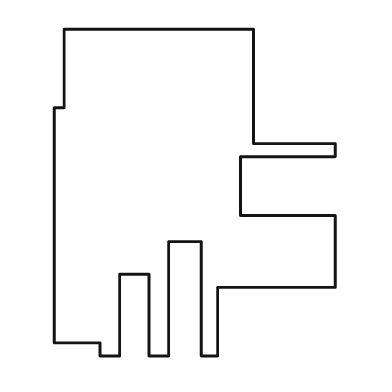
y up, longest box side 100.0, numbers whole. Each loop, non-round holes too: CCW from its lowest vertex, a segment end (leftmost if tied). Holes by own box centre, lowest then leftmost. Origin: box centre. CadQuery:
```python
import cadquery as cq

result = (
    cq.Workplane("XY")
    .moveTo(-29.0, -50.0)
    .lineTo(-23.0, -50.0)
    .lineTo(-23.0, -25.0)
    .lineTo(-14.0, -25.0)
    .lineTo(-14.0, -50.0)
    .lineTo(-8.0, -50.0)
    .lineTo(-8.0, -15.0)
    .lineTo(2.0, -15.0)
    .lineTo(2.0, -50.0)
    .lineTo(7.0, -50.0)
    .lineTo(7.0, -29.0)
    .lineTo(43.0, -29.0)
    .lineTo(43.0, -7.0)
    .lineTo(14.0, -7.0)
    .lineTo(14.0, 11.0)
    .lineTo(43.0, 11.0)
    .lineTo(43.0, 15.0)
    .lineTo(18.0, 15.0)
    .lineTo(18.0, 50.0)
    .lineTo(-40.0, 50.0)
    .lineTo(-40.0, 26.0)
    .lineTo(-43.0, 26.0)
    .lineTo(-43.0, -46.0)
    .lineTo(-29.0, -46.0)
    .close()
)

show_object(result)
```